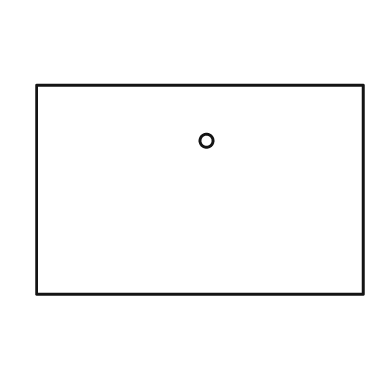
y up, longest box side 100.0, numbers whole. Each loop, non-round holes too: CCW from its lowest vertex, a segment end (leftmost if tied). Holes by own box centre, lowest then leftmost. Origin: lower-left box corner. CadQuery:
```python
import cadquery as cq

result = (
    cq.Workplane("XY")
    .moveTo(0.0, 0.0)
    .lineTo(100.0, 0.0)
    .lineTo(100.0, 64.0)
    .lineTo(0.0, 64.0)
    .close()
    .moveTo(52.0, 47.0)
    .circle(2.0)
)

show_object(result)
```